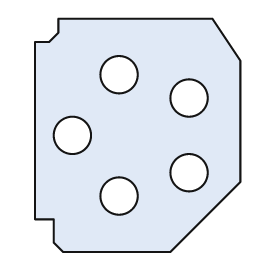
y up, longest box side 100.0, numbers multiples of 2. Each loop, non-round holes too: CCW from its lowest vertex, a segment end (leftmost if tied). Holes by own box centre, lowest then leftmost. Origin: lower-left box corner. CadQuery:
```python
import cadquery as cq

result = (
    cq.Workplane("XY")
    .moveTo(12.0, 0.0)
    .lineTo(58.0, 0.0)
    .lineTo(88.0, 30.0)
    .lineTo(88.0, 82.0)
    .lineTo(76.0, 100.0)
    .lineTo(10.0, 100.0)
    .lineTo(10.0, 94.0)
    .lineTo(6.0, 90.0)
    .lineTo(0.0, 90.0)
    .lineTo(0.0, 14.0)
    .lineTo(8.0, 14.0)
    .lineTo(8.0, 4.0)
    .close()
    .moveTo(36.0, 24.0)
    .circle(8.0)
    .moveTo(66.0, 34.0)
    .circle(8.0)
    .moveTo(16.0, 50.0)
    .circle(8.0)
    .moveTo(66.0, 66.0)
    .circle(8.0)
    .moveTo(36.0, 76.0)
    .circle(8.0)
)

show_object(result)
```